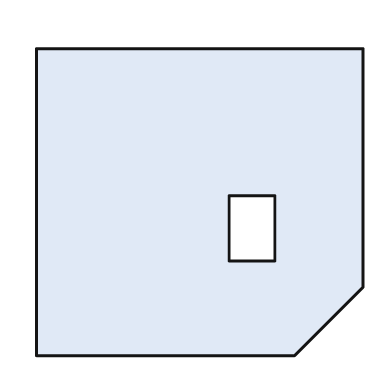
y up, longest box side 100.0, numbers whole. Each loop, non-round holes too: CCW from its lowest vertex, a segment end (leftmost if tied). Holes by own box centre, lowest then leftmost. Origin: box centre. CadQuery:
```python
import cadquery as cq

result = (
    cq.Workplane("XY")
    .moveTo(-50.0, -47.0)
    .lineTo(29.0, -47.0)
    .lineTo(50.0, -26.0)
    .lineTo(50.0, 47.0)
    .lineTo(-50.0, 47.0)
    .close()
    .moveTo(9.0, -18.0)
    .lineTo(23.0, -18.0)
    .lineTo(23.0, 2.0)
    .lineTo(9.0, 2.0)
    .close()
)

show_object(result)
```